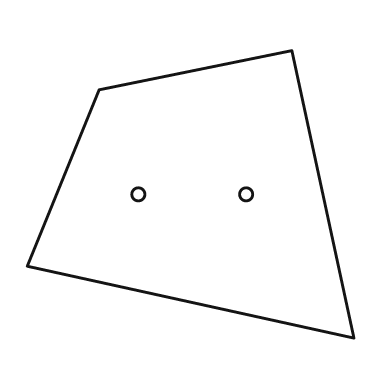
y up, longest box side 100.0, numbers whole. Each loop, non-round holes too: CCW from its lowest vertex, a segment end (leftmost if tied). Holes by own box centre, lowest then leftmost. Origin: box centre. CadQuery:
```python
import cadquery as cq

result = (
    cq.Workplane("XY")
    .moveTo(50.0, -44.0)
    .lineTo(31.0, 44.0)
    .lineTo(-28.0, 32.0)
    .lineTo(-50.0, -22.0)
    .close()
    .moveTo(-16.0, 0.0)
    .circle(2.0)
    .moveTo(17.0, 0.0)
    .circle(2.0)
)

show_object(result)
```